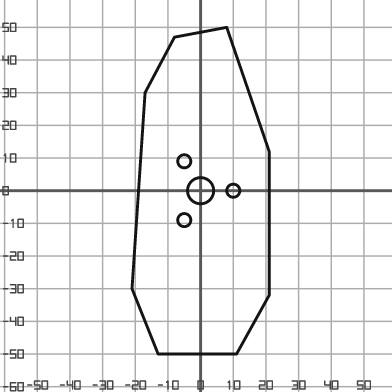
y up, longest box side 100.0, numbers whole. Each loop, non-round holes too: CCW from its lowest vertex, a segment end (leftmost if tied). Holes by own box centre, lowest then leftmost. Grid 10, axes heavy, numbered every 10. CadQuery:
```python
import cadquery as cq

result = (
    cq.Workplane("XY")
    .moveTo(-13.0, -50.0)
    .lineTo(11.0, -50.0)
    .lineTo(21.0, -32.0)
    .lineTo(21.0, 12.0)
    .lineTo(8.0, 50.0)
    .lineTo(-8.0, 47.0)
    .lineTo(-17.0, 30.0)
    .lineTo(-21.0, -30.0)
    .close()
    .moveTo(-5.0, -9.0)
    .circle(2.0)
    .moveTo(0.0, 0.0)
    .circle(4.0)
    .moveTo(10.0, 0.0)
    .circle(2.0)
    .moveTo(-5.0, 9.0)
    .circle(2.0)
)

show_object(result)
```